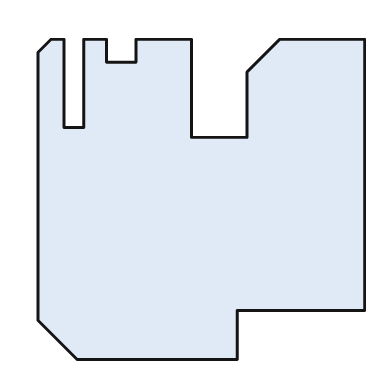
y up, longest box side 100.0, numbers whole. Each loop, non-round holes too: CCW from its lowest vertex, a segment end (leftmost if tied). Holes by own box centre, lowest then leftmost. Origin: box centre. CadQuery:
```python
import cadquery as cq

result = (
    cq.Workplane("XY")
    .moveTo(-38.0, -49.0)
    .lineTo(11.0, -49.0)
    .lineTo(11.0, -34.0)
    .lineTo(50.0, -34.0)
    .lineTo(50.0, 49.0)
    .lineTo(24.0, 49.0)
    .lineTo(14.0, 39.0)
    .lineTo(14.0, 19.0)
    .lineTo(-3.0, 19.0)
    .lineTo(-3.0, 49.0)
    .lineTo(-20.0, 49.0)
    .lineTo(-20.0, 42.0)
    .lineTo(-29.0, 42.0)
    .lineTo(-29.0, 49.0)
    .lineTo(-36.0, 49.0)
    .lineTo(-36.0, 22.0)
    .lineTo(-42.0, 22.0)
    .lineTo(-42.0, 49.0)
    .lineTo(-46.0, 49.0)
    .lineTo(-50.0, 45.0)
    .lineTo(-50.0, -37.0)
    .close()
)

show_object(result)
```